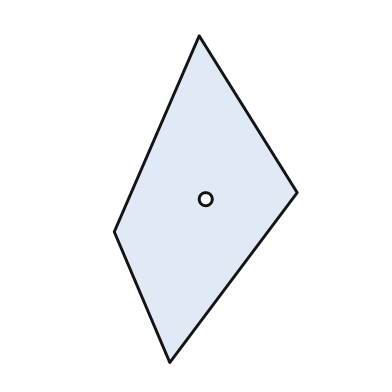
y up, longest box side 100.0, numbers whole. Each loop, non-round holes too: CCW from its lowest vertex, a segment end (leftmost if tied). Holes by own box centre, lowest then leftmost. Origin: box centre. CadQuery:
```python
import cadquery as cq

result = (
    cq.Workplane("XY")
    .moveTo(-11.0, -50.0)
    .lineTo(28.0, 2.0)
    .lineTo(-2.0, 50.0)
    .lineTo(-28.0, -10.0)
    .close()
    .moveTo(0.0, 0.0)
    .circle(2.0)
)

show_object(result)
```